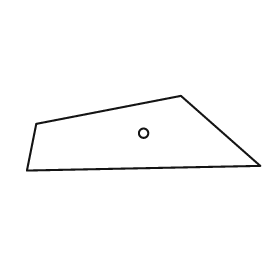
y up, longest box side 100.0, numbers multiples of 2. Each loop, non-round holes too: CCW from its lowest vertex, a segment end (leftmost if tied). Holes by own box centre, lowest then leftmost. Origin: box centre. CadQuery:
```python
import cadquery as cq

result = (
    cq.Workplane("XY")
    .moveTo(-50.0, -16.0)
    .lineTo(50.0, -14.0)
    .lineTo(16.0, 16.0)
    .lineTo(-46.0, 4.0)
    .close()
    .moveTo(0.0, 0.0)
    .circle(2.0)
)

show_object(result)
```